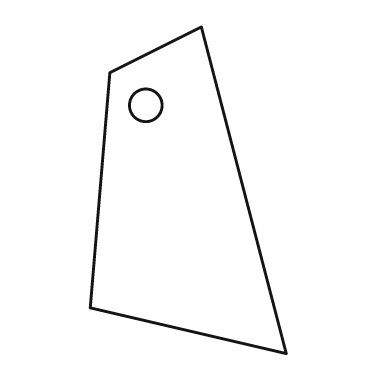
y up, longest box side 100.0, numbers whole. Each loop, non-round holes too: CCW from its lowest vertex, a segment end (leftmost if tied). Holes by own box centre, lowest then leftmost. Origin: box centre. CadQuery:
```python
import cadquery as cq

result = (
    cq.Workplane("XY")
    .moveTo(30.0, -50.0)
    .lineTo(4.0, 50.0)
    .lineTo(-24.0, 36.0)
    .lineTo(-30.0, -36.0)
    .close()
    .moveTo(-13.0, 26.0)
    .circle(5.0)
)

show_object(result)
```